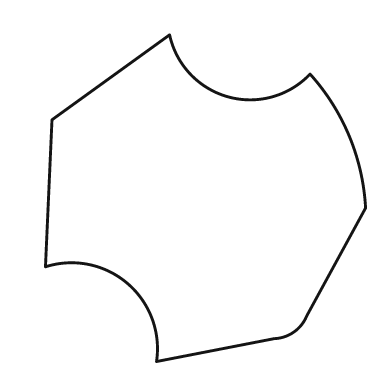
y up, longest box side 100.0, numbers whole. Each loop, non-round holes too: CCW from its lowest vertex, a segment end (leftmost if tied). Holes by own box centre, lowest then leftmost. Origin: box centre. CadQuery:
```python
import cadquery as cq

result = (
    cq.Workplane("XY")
    .moveTo(-15.0, -50.0)
    .lineTo(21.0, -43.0)
    .threePointArc((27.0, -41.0), (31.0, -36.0))
    .lineTo(49.0, -3.0)
    .threePointArc((44.0, 19.0), (32.0, 38.0))
    .threePointArc((7.0, 31.0), (-11.0, 50.0))
    .lineTo(-47.0, 24.0)
    .lineTo(-49.0, -21.0)
    .threePointArc((-24.0, -26.0), (-15.0, -50.0))
    .close()
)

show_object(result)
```